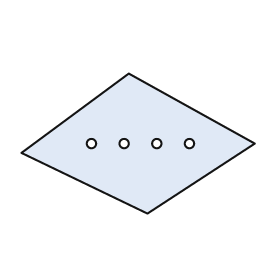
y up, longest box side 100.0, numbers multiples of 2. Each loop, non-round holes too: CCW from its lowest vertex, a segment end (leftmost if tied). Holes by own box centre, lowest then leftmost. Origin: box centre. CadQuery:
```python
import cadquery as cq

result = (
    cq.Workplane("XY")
    .moveTo(4.0, -30.0)
    .lineTo(50.0, 0.0)
    .lineTo(-4.0, 30.0)
    .lineTo(-50.0, -4.0)
    .close()
    .moveTo(-20.0, 0.0)
    .circle(2.0)
    .moveTo(-6.0, 0.0)
    .circle(2.0)
    .moveTo(8.0, 0.0)
    .circle(2.0)
    .moveTo(22.0, 0.0)
    .circle(2.0)
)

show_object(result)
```